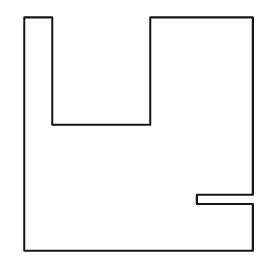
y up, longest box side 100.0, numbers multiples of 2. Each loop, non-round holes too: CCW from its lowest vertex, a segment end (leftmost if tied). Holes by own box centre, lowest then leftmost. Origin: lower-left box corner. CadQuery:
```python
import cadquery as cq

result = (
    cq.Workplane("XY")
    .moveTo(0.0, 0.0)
    .lineTo(98.0, 0.0)
    .lineTo(98.0, 20.0)
    .lineTo(74.0, 20.0)
    .lineTo(74.0, 24.0)
    .lineTo(98.0, 24.0)
    .lineTo(98.0, 100.0)
    .lineTo(54.0, 100.0)
    .lineTo(54.0, 54.0)
    .lineTo(12.0, 54.0)
    .lineTo(12.0, 100.0)
    .lineTo(0.0, 100.0)
    .close()
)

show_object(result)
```